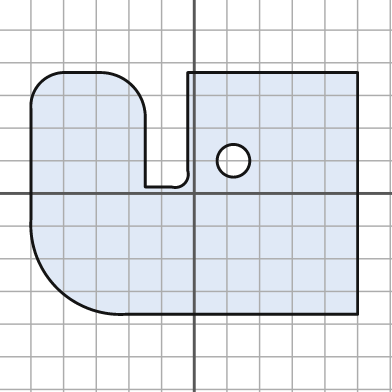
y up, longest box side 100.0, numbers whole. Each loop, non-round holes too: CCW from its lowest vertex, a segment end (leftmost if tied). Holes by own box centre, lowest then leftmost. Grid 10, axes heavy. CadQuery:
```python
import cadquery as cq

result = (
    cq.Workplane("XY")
    .moveTo(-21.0, -37.0)
    .lineTo(50.0, -37.0)
    .lineTo(50.0, 37.0)
    .lineTo(-2.0, 37.0)
    .lineTo(-2.0, 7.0)
    .threePointArc((-3.0, 3.0), (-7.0, 2.0))
    .lineTo(-15.0, 2.0)
    .lineTo(-15.0, 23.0)
    .threePointArc((-19.0, 33.0), (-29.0, 37.0))
    .lineTo(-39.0, 37.0)
    .threePointArc((-47.0, 34.0), (-50.0, 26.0))
    .lineTo(-50.0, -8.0)
    .threePointArc((-42.0, -29.0), (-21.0, -37.0))
    .close()
    .moveTo(12.0, 10.0)
    .circle(5.0)
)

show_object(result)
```